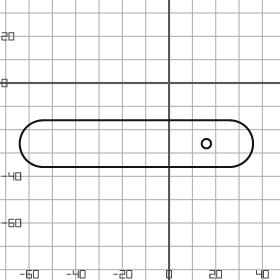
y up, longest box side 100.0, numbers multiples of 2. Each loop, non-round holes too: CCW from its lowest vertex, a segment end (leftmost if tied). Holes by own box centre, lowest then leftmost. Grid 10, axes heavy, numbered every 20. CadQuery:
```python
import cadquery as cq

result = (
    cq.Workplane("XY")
    .moveTo(-54.0, -36.0)
    .lineTo(26.0, -36.0)
    .threePointArc((36.0, -26.0), (26.0, -16.0))
    .lineTo(-54.0, -16.0)
    .threePointArc((-64.0, -26.0), (-54.0, -36.0))
    .close()
    .moveTo(16.0, -26.0)
    .circle(2.0)
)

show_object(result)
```